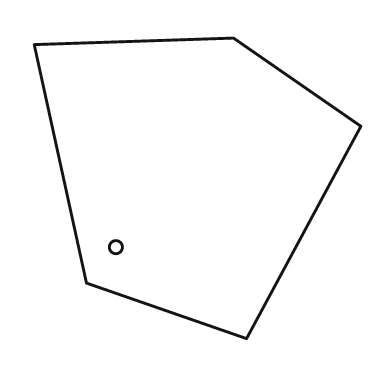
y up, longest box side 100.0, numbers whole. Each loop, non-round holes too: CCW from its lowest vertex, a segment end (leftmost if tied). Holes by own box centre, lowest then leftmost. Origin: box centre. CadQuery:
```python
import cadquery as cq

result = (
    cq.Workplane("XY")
    .moveTo(15.0, -46.0)
    .lineTo(50.0, 19.0)
    .lineTo(11.0, 46.0)
    .lineTo(-50.0, 44.0)
    .lineTo(-34.0, -29.0)
    .close()
    .moveTo(-25.0, -18.0)
    .circle(2.0)
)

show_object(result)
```